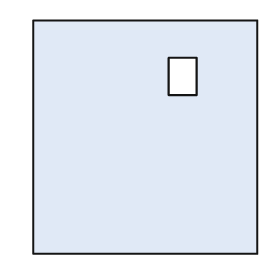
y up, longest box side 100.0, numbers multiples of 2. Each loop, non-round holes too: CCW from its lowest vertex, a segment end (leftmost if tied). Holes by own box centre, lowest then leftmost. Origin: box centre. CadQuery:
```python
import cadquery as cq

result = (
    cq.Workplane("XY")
    .moveTo(-48.0, -50.0)
    .lineTo(48.0, -50.0)
    .lineTo(48.0, 50.0)
    .lineTo(-48.0, 50.0)
    .close()
    .moveTo(10.0, 18.0)
    .lineTo(22.0, 18.0)
    .lineTo(22.0, 34.0)
    .lineTo(10.0, 34.0)
    .close()
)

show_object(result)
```